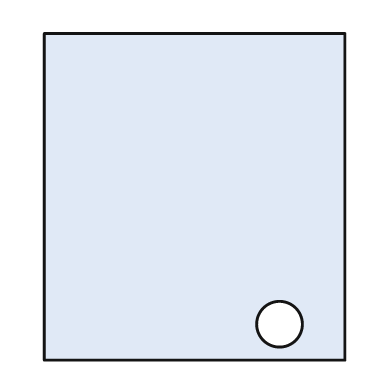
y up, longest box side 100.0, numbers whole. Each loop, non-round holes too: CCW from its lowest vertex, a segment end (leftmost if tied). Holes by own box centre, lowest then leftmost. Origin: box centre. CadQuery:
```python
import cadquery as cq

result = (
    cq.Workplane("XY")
    .moveTo(-46.0, -50.0)
    .lineTo(46.0, -50.0)
    .lineTo(46.0, 50.0)
    .lineTo(-46.0, 50.0)
    .close()
    .moveTo(26.0, -39.0)
    .circle(7.0)
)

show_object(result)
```